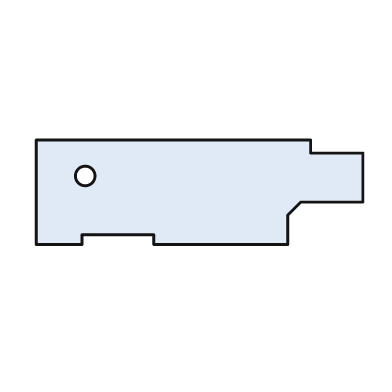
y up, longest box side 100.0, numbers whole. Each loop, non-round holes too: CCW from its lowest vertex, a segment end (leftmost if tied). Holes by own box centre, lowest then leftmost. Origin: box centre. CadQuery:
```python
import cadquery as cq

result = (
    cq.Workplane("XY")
    .moveTo(-50.0, -16.0)
    .lineTo(-36.0, -16.0)
    .lineTo(-36.0, -13.0)
    .lineTo(-14.0, -13.0)
    .lineTo(-14.0, -16.0)
    .lineTo(27.0, -16.0)
    .lineTo(27.0, -7.0)
    .lineTo(31.0, -3.0)
    .lineTo(50.0, -3.0)
    .lineTo(50.0, 12.0)
    .lineTo(34.0, 12.0)
    .lineTo(34.0, 16.0)
    .lineTo(-50.0, 16.0)
    .close()
    .moveTo(-35.0, 5.0)
    .circle(3.0)
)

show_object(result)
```